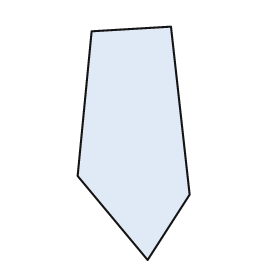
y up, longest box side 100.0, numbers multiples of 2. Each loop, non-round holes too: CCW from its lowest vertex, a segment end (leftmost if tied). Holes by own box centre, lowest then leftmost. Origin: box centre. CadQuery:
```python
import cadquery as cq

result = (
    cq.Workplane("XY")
    .moveTo(6.0, -50.0)
    .lineTo(24.0, -22.0)
    .lineTo(16.0, 50.0)
    .lineTo(-18.0, 48.0)
    .lineTo(-24.0, -14.0)
    .close()
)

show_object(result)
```